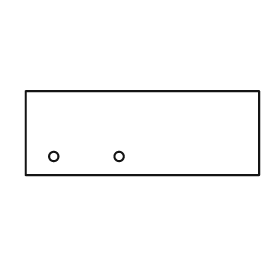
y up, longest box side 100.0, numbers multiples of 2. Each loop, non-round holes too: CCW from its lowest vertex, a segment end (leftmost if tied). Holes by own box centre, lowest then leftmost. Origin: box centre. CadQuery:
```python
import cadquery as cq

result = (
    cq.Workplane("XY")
    .moveTo(-50.0, -18.0)
    .lineTo(50.0, -18.0)
    .lineTo(50.0, 18.0)
    .lineTo(-50.0, 18.0)
    .close()
    .moveTo(-38.0, -10.0)
    .circle(2.0)
    .moveTo(-10.0, -10.0)
    .circle(2.0)
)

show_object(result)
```